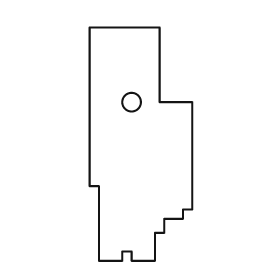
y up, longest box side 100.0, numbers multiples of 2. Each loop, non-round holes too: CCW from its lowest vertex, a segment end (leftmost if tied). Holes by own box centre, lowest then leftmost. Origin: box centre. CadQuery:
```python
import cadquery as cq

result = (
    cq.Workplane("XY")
    .moveTo(-18.0, -50.0)
    .lineTo(-8.0, -50.0)
    .lineTo(-8.0, -46.0)
    .lineTo(-4.0, -46.0)
    .lineTo(-4.0, -50.0)
    .lineTo(6.0, -50.0)
    .lineTo(6.0, -38.0)
    .lineTo(10.0, -38.0)
    .lineTo(10.0, -32.0)
    .lineTo(18.0, -32.0)
    .lineTo(18.0, -28.0)
    .lineTo(22.0, -28.0)
    .lineTo(22.0, 18.0)
    .lineTo(8.0, 18.0)
    .lineTo(8.0, 50.0)
    .lineTo(-22.0, 50.0)
    .lineTo(-22.0, -18.0)
    .lineTo(-18.0, -18.0)
    .close()
    .moveTo(-4.0, 18.0)
    .circle(4.0)
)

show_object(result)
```